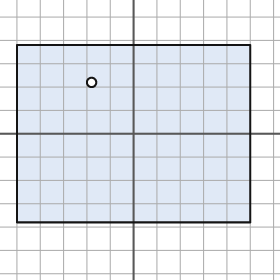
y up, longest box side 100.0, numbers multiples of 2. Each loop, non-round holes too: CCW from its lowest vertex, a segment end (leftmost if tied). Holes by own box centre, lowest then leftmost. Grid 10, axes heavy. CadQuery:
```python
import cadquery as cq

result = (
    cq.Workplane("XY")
    .moveTo(-50.0, -38.0)
    .lineTo(50.0, -38.0)
    .lineTo(50.0, 38.0)
    .lineTo(-50.0, 38.0)
    .close()
    .moveTo(-18.0, 22.0)
    .circle(2.0)
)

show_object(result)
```